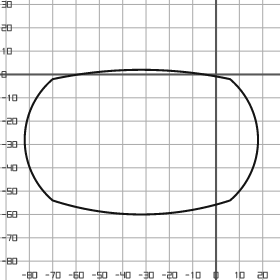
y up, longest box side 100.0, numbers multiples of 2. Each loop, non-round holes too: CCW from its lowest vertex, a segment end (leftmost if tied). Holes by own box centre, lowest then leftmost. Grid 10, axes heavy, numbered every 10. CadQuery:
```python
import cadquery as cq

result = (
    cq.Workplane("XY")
    .moveTo(-70.0, -54.0)
    .threePointArc((-32.0, -60.0), (6.0, -54.0))
    .threePointArc((18.0, -28.0), (6.0, -2.0))
    .threePointArc((-32.0, 2.0), (-70.0, -2.0))
    .threePointArc((-82.0, -28.0), (-70.0, -54.0))
    .close()
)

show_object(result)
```